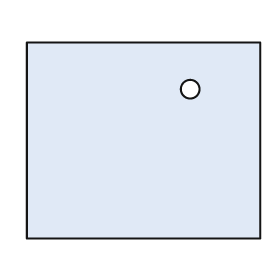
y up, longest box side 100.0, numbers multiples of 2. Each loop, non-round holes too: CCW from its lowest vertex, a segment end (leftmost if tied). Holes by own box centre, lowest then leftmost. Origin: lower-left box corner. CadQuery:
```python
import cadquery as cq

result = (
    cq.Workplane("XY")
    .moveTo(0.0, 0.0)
    .lineTo(100.0, 0.0)
    .lineTo(100.0, 84.0)
    .lineTo(0.0, 84.0)
    .close()
    .moveTo(70.0, 64.0)
    .circle(4.0)
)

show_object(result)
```